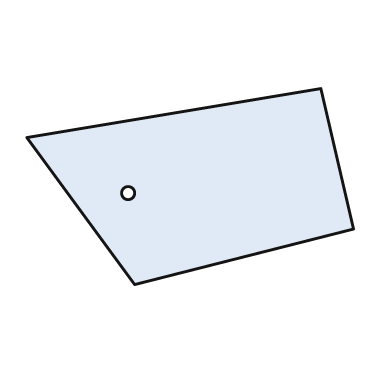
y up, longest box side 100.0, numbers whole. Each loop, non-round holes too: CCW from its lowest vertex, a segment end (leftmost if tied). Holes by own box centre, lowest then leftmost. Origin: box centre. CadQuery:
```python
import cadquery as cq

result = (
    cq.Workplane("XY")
    .moveTo(-17.0, -30.0)
    .lineTo(50.0, -13.0)
    .lineTo(40.0, 30.0)
    .lineTo(-50.0, 15.0)
    .close()
    .moveTo(-19.0, -2.0)
    .circle(2.0)
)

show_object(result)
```